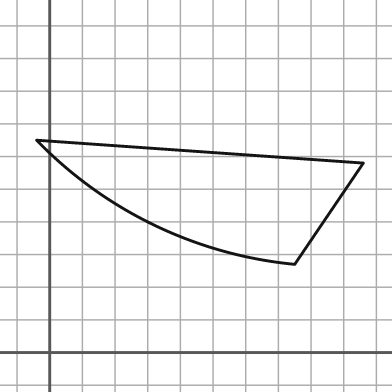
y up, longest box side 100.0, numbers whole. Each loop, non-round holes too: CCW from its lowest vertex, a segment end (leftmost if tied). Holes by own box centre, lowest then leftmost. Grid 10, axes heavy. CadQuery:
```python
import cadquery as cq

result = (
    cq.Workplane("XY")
    .moveTo(75.0, 27.0)
    .lineTo(96.0, 58.0)
    .lineTo(-4.0, 65.0)
    .threePointArc((32.0, 39.0), (75.0, 27.0))
    .close()
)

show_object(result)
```